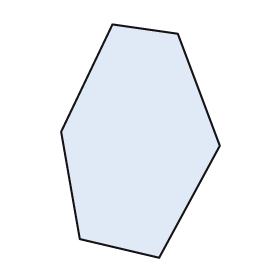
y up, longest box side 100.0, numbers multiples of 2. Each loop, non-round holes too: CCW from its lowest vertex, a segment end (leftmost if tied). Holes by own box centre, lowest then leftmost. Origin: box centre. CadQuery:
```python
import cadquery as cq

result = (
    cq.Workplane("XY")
    .moveTo(8.0, -50.0)
    .lineTo(34.0, -2.0)
    .lineTo(16.0, 46.0)
    .lineTo(-12.0, 50.0)
    .lineTo(-34.0, 4.0)
    .lineTo(-26.0, -42.0)
    .close()
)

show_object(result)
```